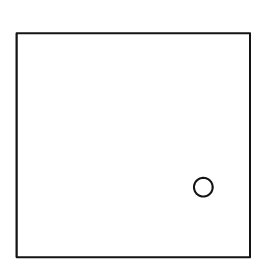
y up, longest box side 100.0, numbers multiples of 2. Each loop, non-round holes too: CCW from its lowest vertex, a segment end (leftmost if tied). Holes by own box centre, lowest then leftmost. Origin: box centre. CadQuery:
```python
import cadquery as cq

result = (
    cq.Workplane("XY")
    .moveTo(-50.0, -48.0)
    .lineTo(50.0, -48.0)
    .lineTo(50.0, 48.0)
    .lineTo(-50.0, 48.0)
    .close()
    .moveTo(30.0, -18.0)
    .circle(4.0)
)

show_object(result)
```